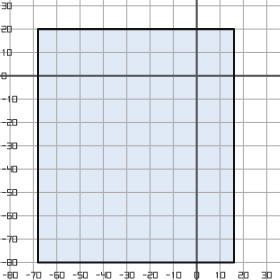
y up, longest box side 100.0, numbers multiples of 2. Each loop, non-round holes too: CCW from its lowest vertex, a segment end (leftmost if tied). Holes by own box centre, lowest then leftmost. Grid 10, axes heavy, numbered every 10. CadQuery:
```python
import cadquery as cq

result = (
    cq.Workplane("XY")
    .moveTo(-68.0, -80.0)
    .lineTo(16.0, -80.0)
    .lineTo(16.0, 20.0)
    .lineTo(-68.0, 20.0)
    .close()
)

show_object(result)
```